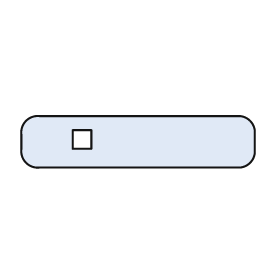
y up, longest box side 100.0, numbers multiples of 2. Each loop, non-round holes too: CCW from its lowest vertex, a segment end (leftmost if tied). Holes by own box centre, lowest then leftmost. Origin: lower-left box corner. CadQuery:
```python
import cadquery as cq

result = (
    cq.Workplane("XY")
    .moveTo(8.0, 0.0)
    .lineTo(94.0, 0.0)
    .threePointArc((98.0, 2.0), (100.0, 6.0))
    .lineTo(100.0, 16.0)
    .threePointArc((98.0, 20.0), (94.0, 22.0))
    .lineTo(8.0, 22.0)
    .threePointArc((2.0, 20.0), (0.0, 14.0))
    .lineTo(0.0, 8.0)
    .threePointArc((2.0, 2.0), (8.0, 0.0))
    .close()
    .moveTo(22.0, 8.0)
    .lineTo(30.0, 8.0)
    .lineTo(30.0, 16.0)
    .lineTo(22.0, 16.0)
    .close()
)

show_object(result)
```